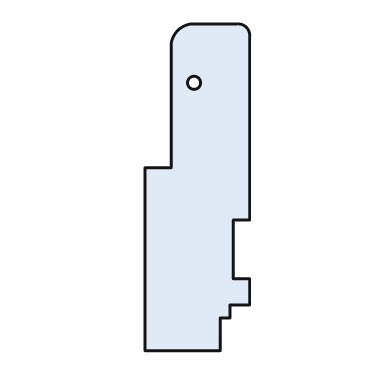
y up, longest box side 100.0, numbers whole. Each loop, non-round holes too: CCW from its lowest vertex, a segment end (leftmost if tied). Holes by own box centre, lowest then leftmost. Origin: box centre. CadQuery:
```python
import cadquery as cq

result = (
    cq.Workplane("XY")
    .moveTo(-16.0, -50.0)
    .lineTo(7.0, -50.0)
    .lineTo(7.0, -40.0)
    .lineTo(10.0, -40.0)
    .lineTo(10.0, -36.0)
    .lineTo(16.0, -36.0)
    .lineTo(16.0, -28.0)
    .lineTo(11.0, -28.0)
    .lineTo(11.0, -10.0)
    .lineTo(16.0, -10.0)
    .lineTo(16.0, 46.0)
    .threePointArc((15.0, 49.0), (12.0, 50.0))
    .lineTo(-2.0, 50.0)
    .threePointArc((-6.0, 48.0), (-8.0, 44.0))
    .lineTo(-8.0, 6.0)
    .lineTo(-16.0, 6.0)
    .close()
    .moveTo(-1.0, 32.0)
    .circle(2.0)
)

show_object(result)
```